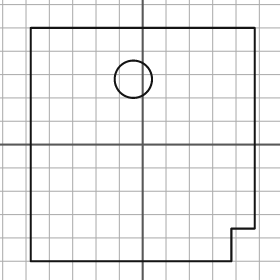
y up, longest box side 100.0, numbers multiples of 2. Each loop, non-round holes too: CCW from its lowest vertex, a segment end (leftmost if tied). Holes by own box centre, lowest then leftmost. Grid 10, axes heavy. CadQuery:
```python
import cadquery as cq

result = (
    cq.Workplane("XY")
    .moveTo(-48.0, -50.0)
    .lineTo(38.0, -50.0)
    .lineTo(38.0, -36.0)
    .lineTo(48.0, -36.0)
    .lineTo(48.0, 50.0)
    .lineTo(-48.0, 50.0)
    .close()
    .moveTo(-4.0, 28.0)
    .circle(8.0)
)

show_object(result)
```